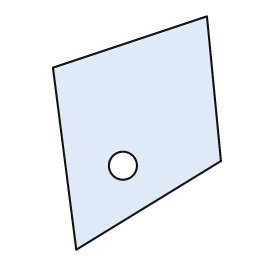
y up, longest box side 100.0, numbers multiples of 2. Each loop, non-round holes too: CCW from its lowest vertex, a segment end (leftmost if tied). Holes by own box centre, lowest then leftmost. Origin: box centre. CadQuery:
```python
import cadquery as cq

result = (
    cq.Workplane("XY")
    .moveTo(-26.0, -50.0)
    .lineTo(36.0, -12.0)
    .lineTo(30.0, 50.0)
    .lineTo(-36.0, 28.0)
    .close()
    .moveTo(-6.0, -14.0)
    .circle(6.0)
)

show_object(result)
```